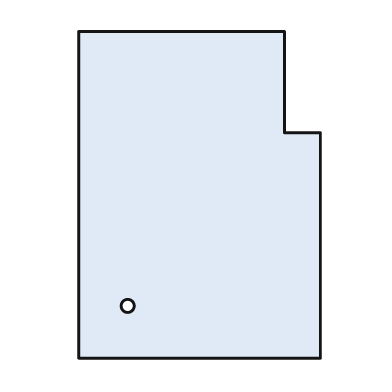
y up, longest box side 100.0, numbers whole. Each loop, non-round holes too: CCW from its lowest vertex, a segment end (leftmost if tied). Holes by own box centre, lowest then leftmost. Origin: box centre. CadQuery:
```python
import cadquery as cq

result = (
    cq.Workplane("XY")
    .moveTo(-37.0, -50.0)
    .lineTo(37.0, -50.0)
    .lineTo(37.0, 19.0)
    .lineTo(26.0, 19.0)
    .lineTo(26.0, 50.0)
    .lineTo(-37.0, 50.0)
    .close()
    .moveTo(-22.0, -34.0)
    .circle(2.0)
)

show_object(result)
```